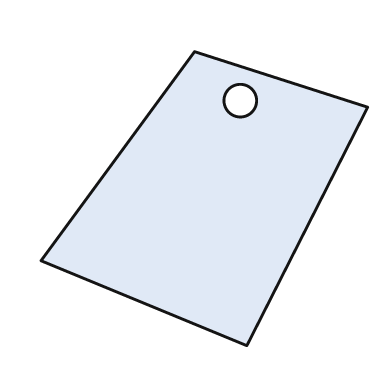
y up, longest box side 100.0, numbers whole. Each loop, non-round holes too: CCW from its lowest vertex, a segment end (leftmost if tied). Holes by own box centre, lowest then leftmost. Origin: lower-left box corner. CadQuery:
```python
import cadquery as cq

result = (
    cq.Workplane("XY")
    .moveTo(63.0, 0.0)
    .lineTo(100.0, 73.0)
    .lineTo(47.0, 90.0)
    .lineTo(0.0, 26.0)
    .close()
    .moveTo(61.0, 75.0)
    .circle(5.0)
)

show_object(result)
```